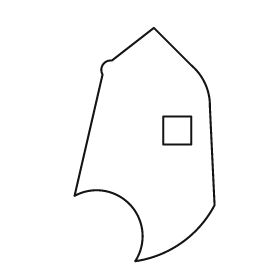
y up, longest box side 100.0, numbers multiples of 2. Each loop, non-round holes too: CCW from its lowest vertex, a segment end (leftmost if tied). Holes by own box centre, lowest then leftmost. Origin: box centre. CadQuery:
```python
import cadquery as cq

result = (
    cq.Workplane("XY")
    .moveTo(-4.0, -50.0)
    .threePointArc((16.0, -42.0), (30.0, -26.0))
    .lineTo(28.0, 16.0)
    .threePointArc((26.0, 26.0), (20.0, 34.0))
    .lineTo(4.0, 50.0)
    .lineTo(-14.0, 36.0)
    .threePointArc((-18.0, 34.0), (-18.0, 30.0))
    .lineTo(-30.0, -22.0)
    .threePointArc((-6.0, -26.0), (-4.0, -50.0))
    .close()
    .moveTo(8.0, 0.0)
    .lineTo(20.0, 0.0)
    .lineTo(20.0, 12.0)
    .lineTo(8.0, 12.0)
    .close()
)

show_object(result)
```